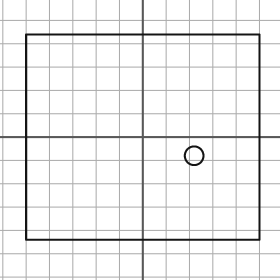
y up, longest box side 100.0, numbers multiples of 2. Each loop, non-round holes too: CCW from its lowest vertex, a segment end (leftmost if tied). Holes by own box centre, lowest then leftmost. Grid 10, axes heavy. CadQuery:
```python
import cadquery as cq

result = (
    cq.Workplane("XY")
    .moveTo(-50.0, -44.0)
    .lineTo(50.0, -44.0)
    .lineTo(50.0, 44.0)
    .lineTo(-50.0, 44.0)
    .close()
    .moveTo(22.0, -8.0)
    .circle(4.0)
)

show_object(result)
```